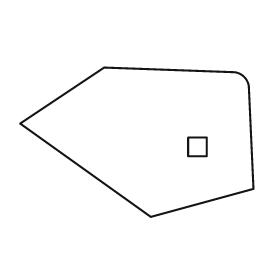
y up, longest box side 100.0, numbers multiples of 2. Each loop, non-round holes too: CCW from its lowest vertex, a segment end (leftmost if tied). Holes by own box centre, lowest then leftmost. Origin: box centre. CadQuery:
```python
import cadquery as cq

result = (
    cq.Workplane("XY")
    .moveTo(6.0, -32.0)
    .lineTo(50.0, -20.0)
    .lineTo(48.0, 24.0)
    .threePointArc((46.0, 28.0), (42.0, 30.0))
    .lineTo(-14.0, 32.0)
    .lineTo(-50.0, 8.0)
    .close()
    .moveTo(22.0, -6.0)
    .lineTo(30.0, -6.0)
    .lineTo(30.0, 2.0)
    .lineTo(22.0, 2.0)
    .close()
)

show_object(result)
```